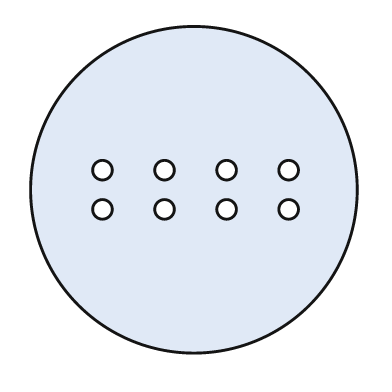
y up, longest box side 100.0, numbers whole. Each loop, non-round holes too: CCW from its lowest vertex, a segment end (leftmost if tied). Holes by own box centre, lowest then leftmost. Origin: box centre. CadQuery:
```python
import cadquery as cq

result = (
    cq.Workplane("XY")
    .moveTo(0.0, 0.0)
    .circle(50.0)
    .moveTo(-28.0, -6.0)
    .circle(3.0)
    .moveTo(-9.0, -6.0)
    .circle(3.0)
    .moveTo(10.0, -6.0)
    .circle(3.0)
    .moveTo(29.0, -6.0)
    .circle(3.0)
    .moveTo(-28.0, 6.0)
    .circle(3.0)
    .moveTo(-9.0, 6.0)
    .circle(3.0)
    .moveTo(10.0, 6.0)
    .circle(3.0)
    .moveTo(29.0, 6.0)
    .circle(3.0)
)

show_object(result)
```